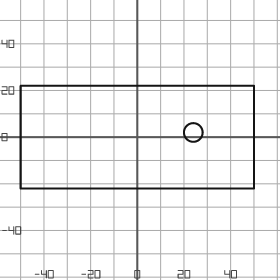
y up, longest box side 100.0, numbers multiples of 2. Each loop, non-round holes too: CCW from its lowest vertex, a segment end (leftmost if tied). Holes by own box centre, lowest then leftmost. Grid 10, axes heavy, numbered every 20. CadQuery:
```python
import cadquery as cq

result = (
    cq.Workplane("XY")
    .moveTo(-50.0, -22.0)
    .lineTo(50.0, -22.0)
    .lineTo(50.0, 22.0)
    .lineTo(-50.0, 22.0)
    .close()
    .moveTo(24.0, 2.0)
    .circle(4.0)
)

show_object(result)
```